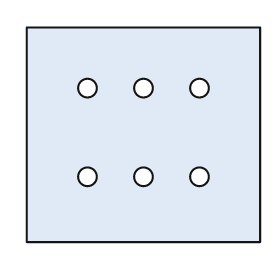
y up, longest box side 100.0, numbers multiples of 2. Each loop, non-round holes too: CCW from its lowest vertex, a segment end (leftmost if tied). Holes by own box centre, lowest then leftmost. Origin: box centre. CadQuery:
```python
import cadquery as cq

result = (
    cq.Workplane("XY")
    .moveTo(-50.0, -46.0)
    .lineTo(50.0, -46.0)
    .lineTo(50.0, 46.0)
    .lineTo(-50.0, 46.0)
    .close()
    .moveTo(-24.0, -18.0)
    .circle(4.0)
    .moveTo(0.0, -18.0)
    .circle(4.0)
    .moveTo(24.0, -18.0)
    .circle(4.0)
    .moveTo(-24.0, 20.0)
    .circle(4.0)
    .moveTo(0.0, 20.0)
    .circle(4.0)
    .moveTo(24.0, 20.0)
    .circle(4.0)
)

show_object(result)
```